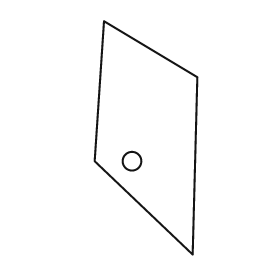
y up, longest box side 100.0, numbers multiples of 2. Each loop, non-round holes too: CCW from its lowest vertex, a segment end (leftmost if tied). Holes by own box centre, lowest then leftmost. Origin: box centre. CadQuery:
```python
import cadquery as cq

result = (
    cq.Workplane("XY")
    .moveTo(20.0, -50.0)
    .lineTo(22.0, 26.0)
    .lineTo(-18.0, 50.0)
    .lineTo(-22.0, -10.0)
    .close()
    .moveTo(-6.0, -10.0)
    .circle(4.0)
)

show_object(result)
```